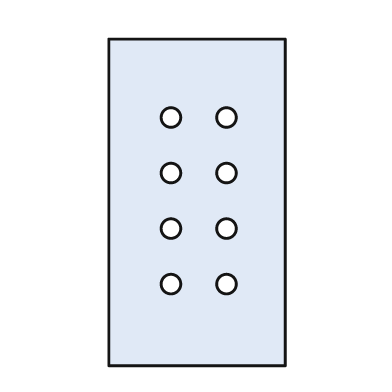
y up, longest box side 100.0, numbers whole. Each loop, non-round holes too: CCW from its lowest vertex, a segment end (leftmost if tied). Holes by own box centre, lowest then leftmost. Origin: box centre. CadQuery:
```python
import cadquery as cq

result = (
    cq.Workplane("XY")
    .moveTo(-27.0, -50.0)
    .lineTo(27.0, -50.0)
    .lineTo(27.0, 50.0)
    .lineTo(-27.0, 50.0)
    .close()
    .moveTo(-8.0, -25.0)
    .circle(3.0)
    .moveTo(9.0, -25.0)
    .circle(3.0)
    .moveTo(-8.0, -8.0)
    .circle(3.0)
    .moveTo(9.0, -8.0)
    .circle(3.0)
    .moveTo(-8.0, 9.0)
    .circle(3.0)
    .moveTo(9.0, 9.0)
    .circle(3.0)
    .moveTo(-8.0, 26.0)
    .circle(3.0)
    .moveTo(9.0, 26.0)
    .circle(3.0)
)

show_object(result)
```